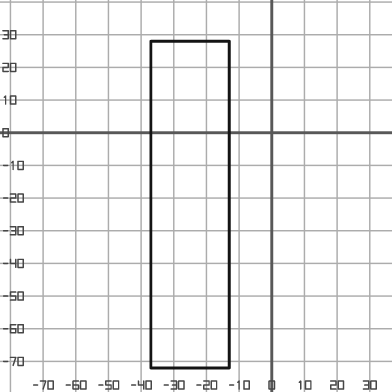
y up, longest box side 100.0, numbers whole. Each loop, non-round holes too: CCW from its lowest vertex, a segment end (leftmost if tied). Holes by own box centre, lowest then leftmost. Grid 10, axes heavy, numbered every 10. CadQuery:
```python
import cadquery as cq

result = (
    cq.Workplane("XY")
    .moveTo(-37.0, -72.0)
    .lineTo(-13.0, -72.0)
    .lineTo(-13.0, 28.0)
    .lineTo(-37.0, 28.0)
    .close()
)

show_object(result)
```